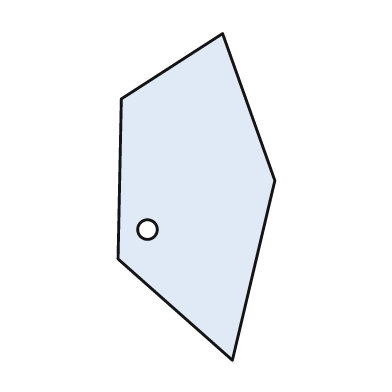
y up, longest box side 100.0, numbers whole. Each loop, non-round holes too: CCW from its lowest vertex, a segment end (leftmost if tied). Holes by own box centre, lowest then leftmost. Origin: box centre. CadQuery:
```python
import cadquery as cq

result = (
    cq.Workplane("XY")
    .moveTo(11.0, -50.0)
    .lineTo(24.0, 5.0)
    .lineTo(8.0, 50.0)
    .lineTo(-23.0, 30.0)
    .lineTo(-24.0, -19.0)
    .close()
    .moveTo(-15.0, -10.0)
    .circle(3.0)
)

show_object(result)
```